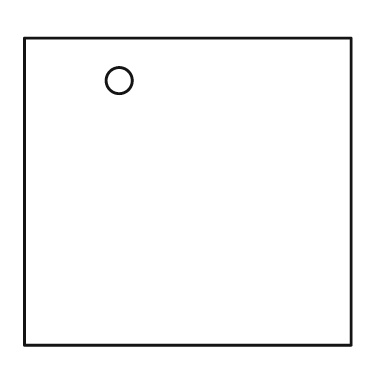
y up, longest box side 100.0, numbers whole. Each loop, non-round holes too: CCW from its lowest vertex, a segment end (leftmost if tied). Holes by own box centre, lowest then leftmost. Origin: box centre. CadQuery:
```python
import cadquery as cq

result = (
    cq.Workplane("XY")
    .moveTo(-50.0, -47.0)
    .lineTo(50.0, -47.0)
    .lineTo(50.0, 47.0)
    .lineTo(-50.0, 47.0)
    .close()
    .moveTo(-21.0, 34.0)
    .circle(4.0)
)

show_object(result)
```